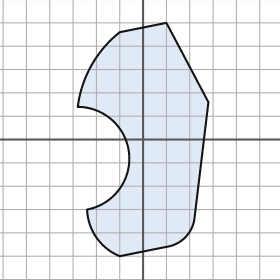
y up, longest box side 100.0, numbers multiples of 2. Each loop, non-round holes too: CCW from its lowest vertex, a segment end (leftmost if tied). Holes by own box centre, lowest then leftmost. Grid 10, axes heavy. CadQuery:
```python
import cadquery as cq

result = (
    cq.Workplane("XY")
    .moveTo(-10.0, -50.0)
    .lineTo(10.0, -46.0)
    .threePointArc((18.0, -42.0), (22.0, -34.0))
    .lineTo(28.0, 16.0)
    .lineTo(10.0, 50.0)
    .lineTo(-10.0, 46.0)
    .threePointArc((-22.0, 32.0), (-28.0, 14.0))
    .threePointArc((-6.0, -6.0), (-24.0, -30.0))
    .threePointArc((-20.0, -42.0), (-10.0, -50.0))
    .close()
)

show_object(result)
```